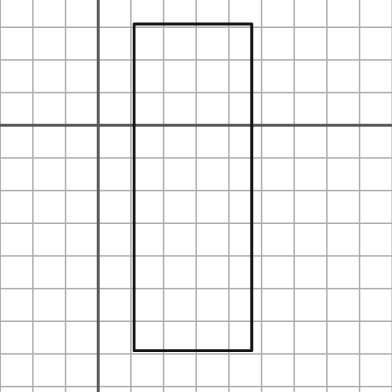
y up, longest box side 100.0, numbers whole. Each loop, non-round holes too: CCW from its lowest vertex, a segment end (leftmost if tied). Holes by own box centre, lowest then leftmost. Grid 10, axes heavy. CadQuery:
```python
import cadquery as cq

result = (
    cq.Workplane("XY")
    .moveTo(11.0, -69.0)
    .lineTo(47.0, -69.0)
    .lineTo(47.0, 31.0)
    .lineTo(11.0, 31.0)
    .close()
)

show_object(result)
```